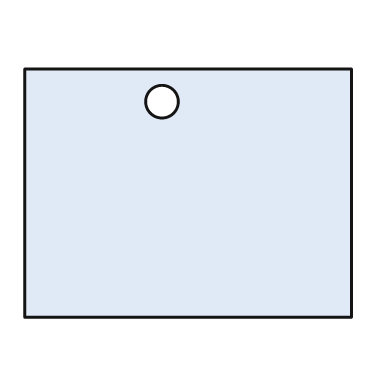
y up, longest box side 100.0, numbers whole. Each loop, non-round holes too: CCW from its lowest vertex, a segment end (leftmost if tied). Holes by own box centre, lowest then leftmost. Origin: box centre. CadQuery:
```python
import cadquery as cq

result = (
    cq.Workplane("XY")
    .moveTo(-50.0, -38.0)
    .lineTo(50.0, -38.0)
    .lineTo(50.0, 38.0)
    .lineTo(-50.0, 38.0)
    .close()
    .moveTo(-8.0, 28.0)
    .circle(5.0)
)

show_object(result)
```